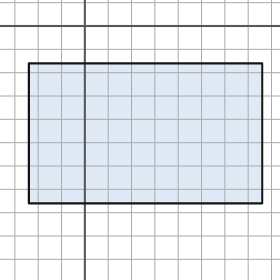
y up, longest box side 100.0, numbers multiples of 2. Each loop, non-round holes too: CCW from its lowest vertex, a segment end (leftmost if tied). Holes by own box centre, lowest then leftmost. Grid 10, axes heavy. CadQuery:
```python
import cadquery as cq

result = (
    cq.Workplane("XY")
    .moveTo(-24.0, -76.0)
    .lineTo(76.0, -76.0)
    .lineTo(76.0, -16.0)
    .lineTo(-24.0, -16.0)
    .close()
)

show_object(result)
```